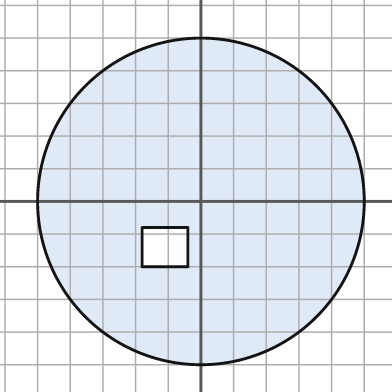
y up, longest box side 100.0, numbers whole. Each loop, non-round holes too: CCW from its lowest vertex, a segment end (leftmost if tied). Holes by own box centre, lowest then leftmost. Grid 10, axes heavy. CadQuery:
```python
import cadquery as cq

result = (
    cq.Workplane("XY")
    .moveTo(0.0, 0.0)
    .circle(50.0)
    .moveTo(-18.0, -20.0)
    .lineTo(-4.0, -20.0)
    .lineTo(-4.0, -8.0)
    .lineTo(-18.0, -8.0)
    .close()
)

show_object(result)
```